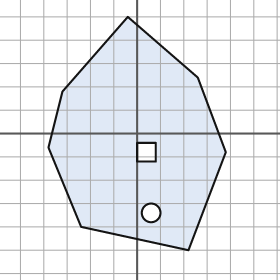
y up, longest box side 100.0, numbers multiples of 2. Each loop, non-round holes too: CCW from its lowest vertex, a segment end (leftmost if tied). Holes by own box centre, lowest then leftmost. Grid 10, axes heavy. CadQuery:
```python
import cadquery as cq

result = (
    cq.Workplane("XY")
    .moveTo(22.0, -50.0)
    .lineTo(38.0, -8.0)
    .lineTo(26.0, 24.0)
    .lineTo(-4.0, 50.0)
    .lineTo(-32.0, 18.0)
    .lineTo(-38.0, -6.0)
    .lineTo(-24.0, -40.0)
    .close()
    .moveTo(6.0, -34.0)
    .circle(4.0)
    .moveTo(0.0, -12.0)
    .lineTo(8.0, -12.0)
    .lineTo(8.0, -4.0)
    .lineTo(0.0, -4.0)
    .close()
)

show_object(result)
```